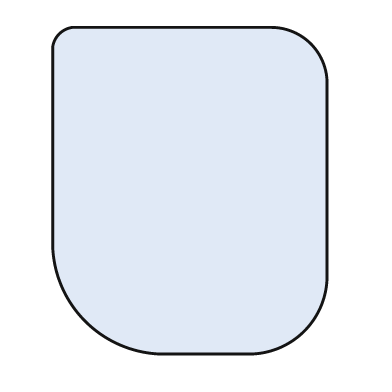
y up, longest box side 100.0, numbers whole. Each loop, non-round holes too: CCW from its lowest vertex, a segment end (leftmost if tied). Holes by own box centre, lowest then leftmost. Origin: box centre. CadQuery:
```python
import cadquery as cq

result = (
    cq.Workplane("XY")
    .moveTo(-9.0, -50.0)
    .lineTo(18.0, -50.0)
    .threePointArc((35.0, -43.0), (42.0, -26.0))
    .lineTo(42.0, 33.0)
    .threePointArc((37.0, 45.0), (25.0, 50.0))
    .lineTo(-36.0, 50.0)
    .threePointArc((-40.0, 48.0), (-42.0, 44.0))
    .lineTo(-42.0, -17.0)
    .threePointArc((-32.0, -40.0), (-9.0, -50.0))
    .close()
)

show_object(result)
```